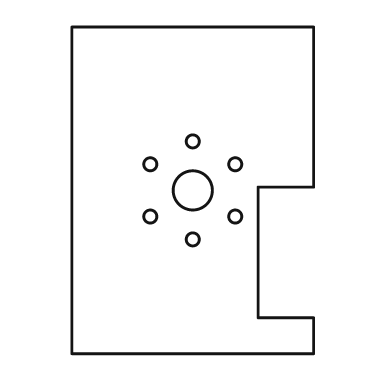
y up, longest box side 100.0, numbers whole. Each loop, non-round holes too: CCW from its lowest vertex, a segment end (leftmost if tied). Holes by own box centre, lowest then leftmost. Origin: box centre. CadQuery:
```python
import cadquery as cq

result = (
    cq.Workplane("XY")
    .moveTo(-37.0, -50.0)
    .lineTo(37.0, -50.0)
    .lineTo(37.0, -39.0)
    .lineTo(20.0, -39.0)
    .lineTo(20.0, 1.0)
    .lineTo(37.0, 1.0)
    .lineTo(37.0, 50.0)
    .lineTo(-37.0, 50.0)
    .close()
    .moveTo(0.0, -15.0)
    .circle(2.0)
    .moveTo(-13.0, -8.0)
    .circle(2.0)
    .moveTo(13.0, -8.0)
    .circle(2.0)
    .moveTo(0.0, 0.0)
    .circle(6.0)
    .moveTo(-13.0, 8.0)
    .circle(2.0)
    .moveTo(13.0, 8.0)
    .circle(2.0)
    .moveTo(0.0, 15.0)
    .circle(2.0)
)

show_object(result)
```